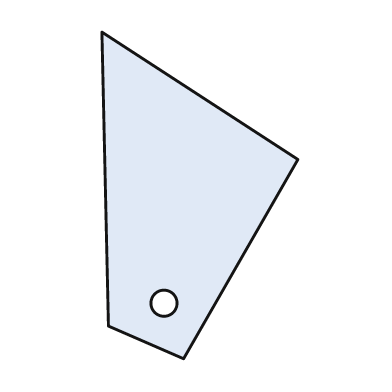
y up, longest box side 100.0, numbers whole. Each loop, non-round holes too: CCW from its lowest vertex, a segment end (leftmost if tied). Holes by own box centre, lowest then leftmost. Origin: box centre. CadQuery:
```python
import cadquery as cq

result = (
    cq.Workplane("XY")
    .moveTo(-5.0, -50.0)
    .lineTo(30.0, 11.0)
    .lineTo(-30.0, 50.0)
    .lineTo(-28.0, -40.0)
    .close()
    .moveTo(-11.0, -33.0)
    .circle(4.0)
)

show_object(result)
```